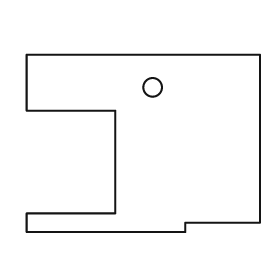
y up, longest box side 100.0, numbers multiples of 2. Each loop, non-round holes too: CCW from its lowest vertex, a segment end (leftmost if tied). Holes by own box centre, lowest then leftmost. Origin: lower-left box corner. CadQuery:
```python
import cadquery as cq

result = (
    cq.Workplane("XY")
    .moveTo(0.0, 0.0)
    .lineTo(68.0, 0.0)
    .lineTo(68.0, 4.0)
    .lineTo(100.0, 4.0)
    .lineTo(100.0, 76.0)
    .lineTo(0.0, 76.0)
    .lineTo(0.0, 52.0)
    .lineTo(38.0, 52.0)
    .lineTo(38.0, 8.0)
    .lineTo(0.0, 8.0)
    .close()
    .moveTo(54.0, 62.0)
    .circle(4.0)
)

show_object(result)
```